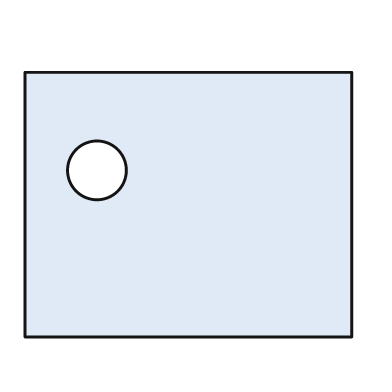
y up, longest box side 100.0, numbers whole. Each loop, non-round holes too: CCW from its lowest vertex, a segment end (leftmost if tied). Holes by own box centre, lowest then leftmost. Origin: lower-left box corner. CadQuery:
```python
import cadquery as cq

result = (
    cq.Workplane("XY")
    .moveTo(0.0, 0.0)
    .lineTo(100.0, 0.0)
    .lineTo(100.0, 81.0)
    .lineTo(0.0, 81.0)
    .close()
    .moveTo(22.0, 51.0)
    .circle(9.0)
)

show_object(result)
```